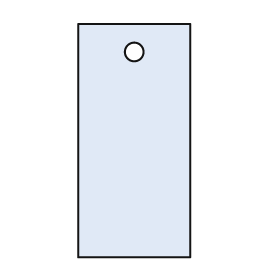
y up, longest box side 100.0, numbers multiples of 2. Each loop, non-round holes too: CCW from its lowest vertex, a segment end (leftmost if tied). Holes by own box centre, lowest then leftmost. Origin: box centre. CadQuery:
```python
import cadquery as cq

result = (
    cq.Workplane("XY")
    .moveTo(-24.0, -50.0)
    .lineTo(24.0, -50.0)
    .lineTo(24.0, 50.0)
    .lineTo(-24.0, 50.0)
    .close()
    .moveTo(0.0, 38.0)
    .circle(4.0)
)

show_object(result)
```